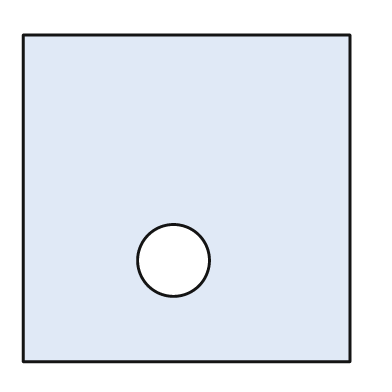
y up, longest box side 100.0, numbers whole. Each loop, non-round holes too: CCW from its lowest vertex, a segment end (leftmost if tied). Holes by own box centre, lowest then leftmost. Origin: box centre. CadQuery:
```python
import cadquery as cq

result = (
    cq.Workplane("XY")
    .moveTo(-50.0, -50.0)
    .lineTo(50.0, -50.0)
    .lineTo(50.0, 50.0)
    .lineTo(-50.0, 50.0)
    .close()
    .moveTo(-4.0, -19.0)
    .circle(11.0)
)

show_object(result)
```